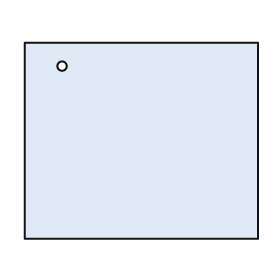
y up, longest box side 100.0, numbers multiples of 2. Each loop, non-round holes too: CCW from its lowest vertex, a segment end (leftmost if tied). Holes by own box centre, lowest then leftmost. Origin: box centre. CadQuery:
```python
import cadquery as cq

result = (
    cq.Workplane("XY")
    .moveTo(-50.0, -42.0)
    .lineTo(50.0, -42.0)
    .lineTo(50.0, 42.0)
    .lineTo(-50.0, 42.0)
    .close()
    .moveTo(-34.0, 32.0)
    .circle(2.0)
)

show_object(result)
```